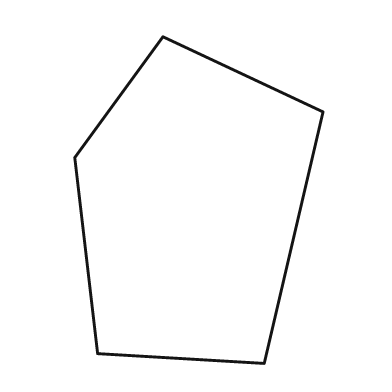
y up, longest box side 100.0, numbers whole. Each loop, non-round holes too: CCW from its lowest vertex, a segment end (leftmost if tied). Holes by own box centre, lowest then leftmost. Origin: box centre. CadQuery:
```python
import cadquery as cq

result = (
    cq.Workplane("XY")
    .moveTo(20.0, -50.0)
    .lineTo(38.0, 27.0)
    .lineTo(-11.0, 50.0)
    .lineTo(-38.0, 13.0)
    .lineTo(-31.0, -47.0)
    .close()
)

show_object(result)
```